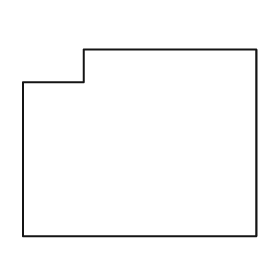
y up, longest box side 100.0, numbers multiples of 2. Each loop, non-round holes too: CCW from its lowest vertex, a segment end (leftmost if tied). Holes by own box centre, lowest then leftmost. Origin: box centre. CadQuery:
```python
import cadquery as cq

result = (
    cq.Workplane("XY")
    .moveTo(-50.0, -40.0)
    .lineTo(50.0, -40.0)
    .lineTo(50.0, 40.0)
    .lineTo(-24.0, 40.0)
    .lineTo(-24.0, 26.0)
    .lineTo(-50.0, 26.0)
    .close()
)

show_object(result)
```